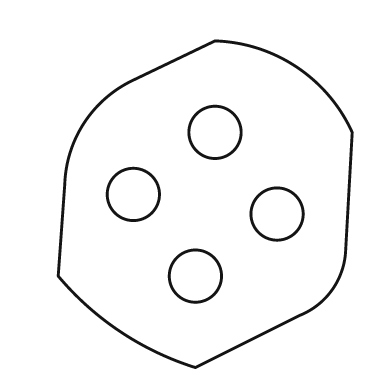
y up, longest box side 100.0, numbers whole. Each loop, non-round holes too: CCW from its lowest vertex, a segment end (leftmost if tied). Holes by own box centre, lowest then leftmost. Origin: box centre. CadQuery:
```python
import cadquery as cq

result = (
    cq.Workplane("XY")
    .moveTo(-3.0, -50.0)
    .lineTo(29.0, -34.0)
    .threePointArc((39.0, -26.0), (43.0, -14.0))
    .lineTo(45.0, 22.0)
    .threePointArc((28.0, 42.0), (3.0, 50.0))
    .lineTo(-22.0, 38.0)
    .threePointArc((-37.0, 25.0), (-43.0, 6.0))
    .lineTo(-45.0, -22.0)
    .threePointArc((-26.0, -39.0), (-3.0, -50.0))
    .close()
    .moveTo(-3.0, -22.0)
    .circle(8.0)
    .moveTo(22.0, -3.0)
    .circle(8.0)
    .moveTo(-22.0, 3.0)
    .circle(8.0)
    .moveTo(3.0, 22.0)
    .circle(8.0)
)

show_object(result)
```